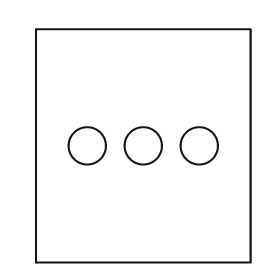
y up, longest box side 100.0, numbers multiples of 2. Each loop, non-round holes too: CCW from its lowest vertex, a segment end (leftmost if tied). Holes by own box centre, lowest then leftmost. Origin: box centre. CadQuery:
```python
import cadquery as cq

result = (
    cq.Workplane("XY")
    .moveTo(-46.0, -50.0)
    .lineTo(46.0, -50.0)
    .lineTo(46.0, 50.0)
    .lineTo(-46.0, 50.0)
    .close()
    .moveTo(-24.0, 0.0)
    .circle(8.0)
    .moveTo(0.0, 0.0)
    .circle(8.0)
    .moveTo(24.0, 0.0)
    .circle(8.0)
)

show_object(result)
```